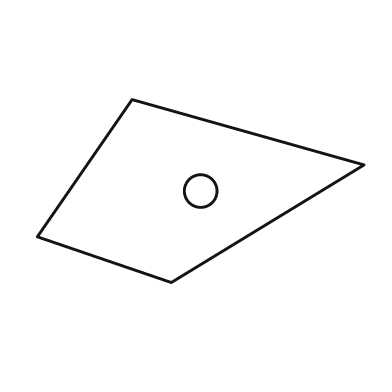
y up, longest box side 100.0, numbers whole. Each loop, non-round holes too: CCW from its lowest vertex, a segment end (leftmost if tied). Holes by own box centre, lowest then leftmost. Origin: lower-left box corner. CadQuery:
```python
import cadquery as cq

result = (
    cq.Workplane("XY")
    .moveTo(41.0, 0.0)
    .lineTo(100.0, 36.0)
    .lineTo(29.0, 56.0)
    .lineTo(0.0, 14.0)
    .close()
    .moveTo(50.0, 28.0)
    .circle(5.0)
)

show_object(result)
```